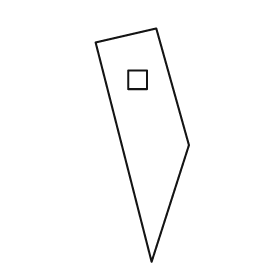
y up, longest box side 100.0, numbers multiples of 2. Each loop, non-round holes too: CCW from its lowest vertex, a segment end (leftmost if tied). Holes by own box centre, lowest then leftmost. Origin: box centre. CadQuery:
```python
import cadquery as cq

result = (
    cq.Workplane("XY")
    .moveTo(4.0, -50.0)
    .lineTo(20.0, 0.0)
    .lineTo(6.0, 50.0)
    .lineTo(-20.0, 44.0)
    .close()
    .moveTo(-6.0, 24.0)
    .lineTo(2.0, 24.0)
    .lineTo(2.0, 32.0)
    .lineTo(-6.0, 32.0)
    .close()
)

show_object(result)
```